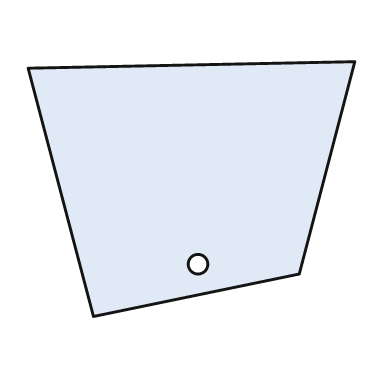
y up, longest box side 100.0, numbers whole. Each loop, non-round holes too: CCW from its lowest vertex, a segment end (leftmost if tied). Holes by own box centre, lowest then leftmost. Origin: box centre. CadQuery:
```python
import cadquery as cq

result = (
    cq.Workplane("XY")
    .moveTo(-30.0, -39.0)
    .lineTo(33.0, -26.0)
    .lineTo(50.0, 39.0)
    .lineTo(-50.0, 37.0)
    .close()
    .moveTo(2.0, -23.0)
    .circle(3.0)
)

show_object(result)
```